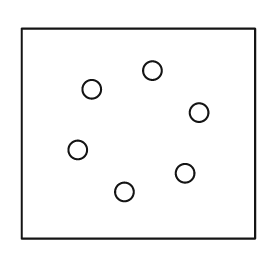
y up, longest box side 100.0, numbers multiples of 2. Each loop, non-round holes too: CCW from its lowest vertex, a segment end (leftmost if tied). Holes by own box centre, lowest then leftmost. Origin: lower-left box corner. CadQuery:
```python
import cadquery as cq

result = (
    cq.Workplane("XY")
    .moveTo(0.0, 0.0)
    .lineTo(100.0, 0.0)
    .lineTo(100.0, 90.0)
    .lineTo(0.0, 90.0)
    .close()
    .moveTo(44.0, 20.0)
    .circle(4.0)
    .moveTo(70.0, 28.0)
    .circle(4.0)
    .moveTo(24.0, 38.0)
    .circle(4.0)
    .moveTo(76.0, 54.0)
    .circle(4.0)
    .moveTo(30.0, 64.0)
    .circle(4.0)
    .moveTo(56.0, 72.0)
    .circle(4.0)
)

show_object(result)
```